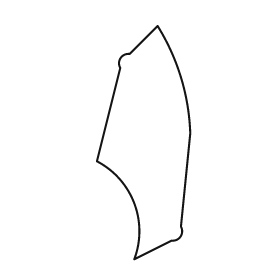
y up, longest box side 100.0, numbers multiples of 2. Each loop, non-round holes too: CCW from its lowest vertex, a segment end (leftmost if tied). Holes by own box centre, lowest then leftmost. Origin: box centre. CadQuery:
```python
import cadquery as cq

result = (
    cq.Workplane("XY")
    .moveTo(-4.0, -50.0)
    .lineTo(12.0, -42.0)
    .threePointArc((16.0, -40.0), (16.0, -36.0))
    .lineTo(20.0, 4.0)
    .threePointArc((16.0, 28.0), (6.0, 50.0))
    .lineTo(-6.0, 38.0)
    .threePointArc((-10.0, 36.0), (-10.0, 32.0))
    .lineTo(-20.0, -8.0)
    .threePointArc((-4.0, -26.0), (-4.0, -50.0))
    .close()
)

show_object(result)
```